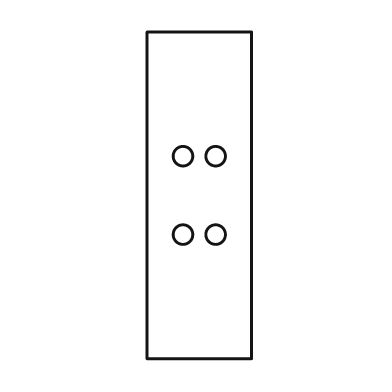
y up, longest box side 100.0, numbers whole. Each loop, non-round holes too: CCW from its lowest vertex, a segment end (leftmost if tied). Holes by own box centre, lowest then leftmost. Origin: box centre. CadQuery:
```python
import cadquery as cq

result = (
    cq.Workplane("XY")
    .moveTo(-16.0, -50.0)
    .lineTo(16.0, -50.0)
    .lineTo(16.0, 50.0)
    .lineTo(-16.0, 50.0)
    .close()
    .moveTo(-5.0, -12.0)
    .circle(3.0)
    .moveTo(5.0, -12.0)
    .circle(3.0)
    .moveTo(-5.0, 12.0)
    .circle(3.0)
    .moveTo(5.0, 12.0)
    .circle(3.0)
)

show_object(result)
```